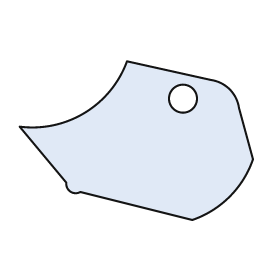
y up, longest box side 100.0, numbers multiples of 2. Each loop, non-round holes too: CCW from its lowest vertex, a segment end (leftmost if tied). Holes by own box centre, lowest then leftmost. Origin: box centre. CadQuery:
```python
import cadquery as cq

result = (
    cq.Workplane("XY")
    .moveTo(24.0, -34.0)
    .threePointArc((40.0, -24.0), (50.0, -8.0))
    .lineTo(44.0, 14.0)
    .threePointArc((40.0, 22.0), (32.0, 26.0))
    .lineTo(-4.0, 34.0)
    .threePointArc((-22.0, 12.0), (-50.0, 6.0))
    .lineTo(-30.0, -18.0)
    .threePointArc((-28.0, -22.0), (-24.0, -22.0))
    .close()
    .moveTo(20.0, 18.0)
    .circle(6.0)
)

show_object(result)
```